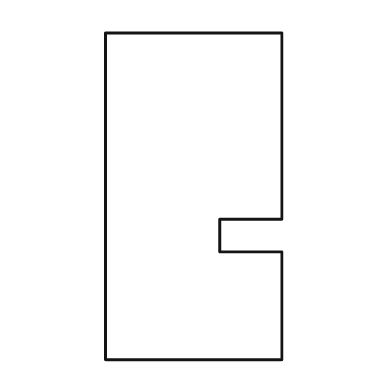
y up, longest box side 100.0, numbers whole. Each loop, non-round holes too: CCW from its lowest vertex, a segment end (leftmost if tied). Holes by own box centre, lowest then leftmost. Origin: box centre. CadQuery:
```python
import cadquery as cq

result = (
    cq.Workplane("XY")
    .moveTo(-27.0, -50.0)
    .lineTo(27.0, -50.0)
    .lineTo(27.0, -17.0)
    .lineTo(8.0, -17.0)
    .lineTo(8.0, -7.0)
    .lineTo(27.0, -7.0)
    .lineTo(27.0, 50.0)
    .lineTo(-27.0, 50.0)
    .close()
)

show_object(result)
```